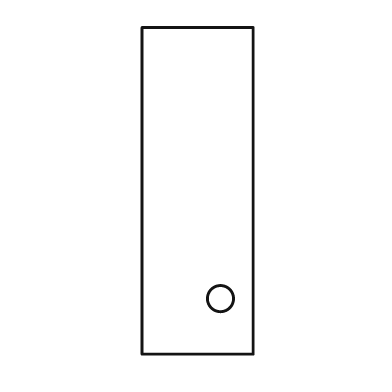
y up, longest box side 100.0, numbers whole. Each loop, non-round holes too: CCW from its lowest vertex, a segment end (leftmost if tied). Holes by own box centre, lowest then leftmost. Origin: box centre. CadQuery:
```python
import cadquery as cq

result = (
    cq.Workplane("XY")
    .moveTo(-17.0, -50.0)
    .lineTo(17.0, -50.0)
    .lineTo(17.0, 50.0)
    .lineTo(-17.0, 50.0)
    .close()
    .moveTo(7.0, -33.0)
    .circle(4.0)
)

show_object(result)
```